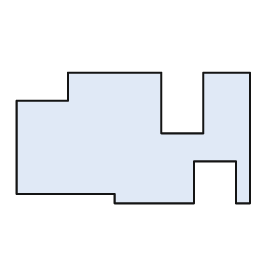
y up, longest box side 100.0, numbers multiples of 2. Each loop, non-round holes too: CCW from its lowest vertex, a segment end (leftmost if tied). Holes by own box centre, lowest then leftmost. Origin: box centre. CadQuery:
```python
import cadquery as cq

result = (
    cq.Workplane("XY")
    .moveTo(-8.0, -28.0)
    .lineTo(26.0, -28.0)
    .lineTo(26.0, -10.0)
    .lineTo(44.0, -10.0)
    .lineTo(44.0, -28.0)
    .lineTo(50.0, -28.0)
    .lineTo(50.0, 28.0)
    .lineTo(30.0, 28.0)
    .lineTo(30.0, 2.0)
    .lineTo(12.0, 2.0)
    .lineTo(12.0, 28.0)
    .lineTo(-28.0, 28.0)
    .lineTo(-28.0, 16.0)
    .lineTo(-50.0, 16.0)
    .lineTo(-50.0, -24.0)
    .lineTo(-8.0, -24.0)
    .close()
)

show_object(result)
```